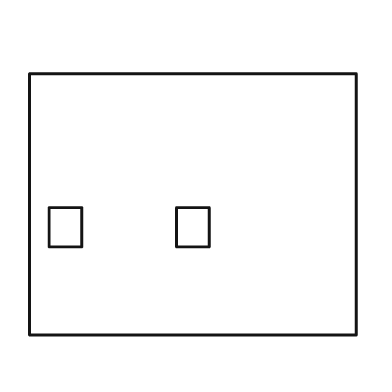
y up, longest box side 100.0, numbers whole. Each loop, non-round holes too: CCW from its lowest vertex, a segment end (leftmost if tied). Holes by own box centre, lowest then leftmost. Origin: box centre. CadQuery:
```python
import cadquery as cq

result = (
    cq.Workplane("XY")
    .moveTo(-50.0, -40.0)
    .lineTo(50.0, -40.0)
    .lineTo(50.0, 40.0)
    .lineTo(-50.0, 40.0)
    .close()
    .moveTo(-44.0, -13.0)
    .lineTo(-34.0, -13.0)
    .lineTo(-34.0, -1.0)
    .lineTo(-44.0, -1.0)
    .close()
    .moveTo(-5.0, -13.0)
    .lineTo(5.0, -13.0)
    .lineTo(5.0, -1.0)
    .lineTo(-5.0, -1.0)
    .close()
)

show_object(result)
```